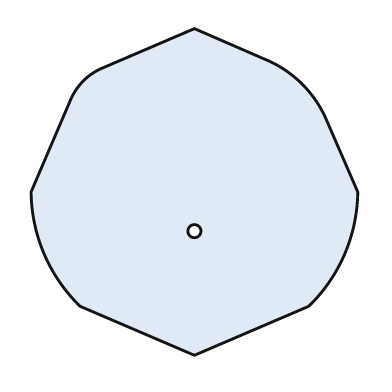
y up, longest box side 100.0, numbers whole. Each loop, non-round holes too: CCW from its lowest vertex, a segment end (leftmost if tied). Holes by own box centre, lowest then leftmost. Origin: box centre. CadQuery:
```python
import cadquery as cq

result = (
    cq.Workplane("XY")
    .moveTo(0.0, -50.0)
    .lineTo(35.0, -35.0)
    .threePointArc((46.0, -19.0), (50.0, 0.0))
    .lineTo(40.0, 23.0)
    .threePointArc((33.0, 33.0), (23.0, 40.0))
    .lineTo(0.0, 50.0)
    .lineTo(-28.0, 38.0)
    .threePointArc((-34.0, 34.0), (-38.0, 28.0))
    .lineTo(-50.0, 0.0)
    .threePointArc((-46.0, -19.0), (-35.0, -35.0))
    .close()
    .moveTo(0.0, -12.0)
    .circle(2.0)
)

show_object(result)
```